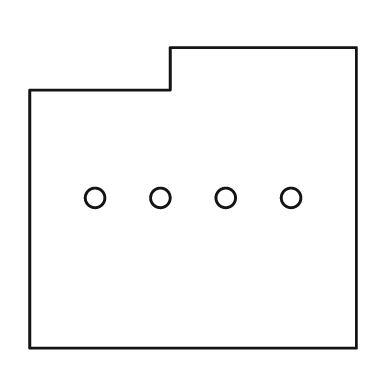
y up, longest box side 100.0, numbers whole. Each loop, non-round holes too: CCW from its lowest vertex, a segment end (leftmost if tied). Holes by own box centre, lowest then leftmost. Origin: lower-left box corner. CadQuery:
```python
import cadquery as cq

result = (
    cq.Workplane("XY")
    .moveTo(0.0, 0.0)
    .lineTo(100.0, 0.0)
    .lineTo(100.0, 92.0)
    .lineTo(43.0, 92.0)
    .lineTo(43.0, 79.0)
    .lineTo(0.0, 79.0)
    .close()
    .moveTo(20.0, 46.0)
    .circle(3.0)
    .moveTo(40.0, 46.0)
    .circle(3.0)
    .moveTo(60.0, 46.0)
    .circle(3.0)
    .moveTo(80.0, 46.0)
    .circle(3.0)
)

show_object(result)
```